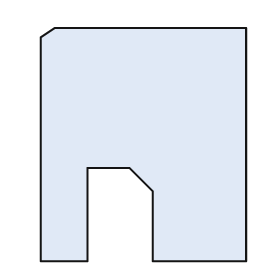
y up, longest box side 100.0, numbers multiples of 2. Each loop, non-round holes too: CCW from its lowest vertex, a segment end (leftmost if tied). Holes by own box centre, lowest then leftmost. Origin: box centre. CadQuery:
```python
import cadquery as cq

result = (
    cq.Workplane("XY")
    .moveTo(-44.0, -50.0)
    .lineTo(-24.0, -50.0)
    .lineTo(-24.0, -10.0)
    .lineTo(-6.0, -10.0)
    .lineTo(4.0, -20.0)
    .lineTo(4.0, -50.0)
    .lineTo(44.0, -50.0)
    .lineTo(44.0, 50.0)
    .lineTo(-38.0, 50.0)
    .lineTo(-44.0, 46.0)
    .close()
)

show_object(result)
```